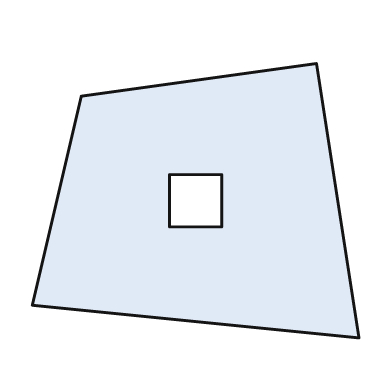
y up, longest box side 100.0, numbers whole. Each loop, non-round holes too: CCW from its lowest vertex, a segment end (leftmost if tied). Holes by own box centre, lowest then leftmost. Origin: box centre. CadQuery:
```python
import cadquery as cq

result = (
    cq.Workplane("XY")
    .moveTo(50.0, -42.0)
    .lineTo(37.0, 42.0)
    .lineTo(-35.0, 32.0)
    .lineTo(-50.0, -32.0)
    .close()
    .moveTo(-8.0, -8.0)
    .lineTo(8.0, -8.0)
    .lineTo(8.0, 8.0)
    .lineTo(-8.0, 8.0)
    .close()
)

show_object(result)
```